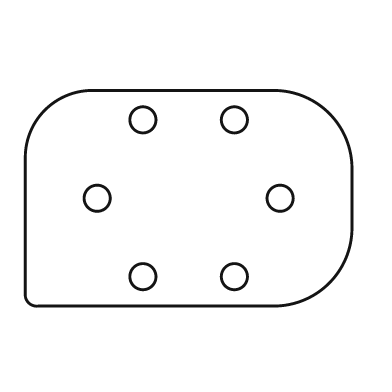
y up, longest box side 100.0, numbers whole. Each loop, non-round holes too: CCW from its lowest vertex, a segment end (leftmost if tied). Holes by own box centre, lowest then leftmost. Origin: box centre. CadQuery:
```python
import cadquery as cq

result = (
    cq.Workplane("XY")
    .moveTo(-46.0, -33.0)
    .lineTo(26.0, -33.0)
    .threePointArc((43.0, -26.0), (50.0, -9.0))
    .lineTo(50.0, 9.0)
    .threePointArc((43.0, 26.0), (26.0, 33.0))
    .lineTo(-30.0, 33.0)
    .threePointArc((-44.0, 27.0), (-50.0, 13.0))
    .lineTo(-50.0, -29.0)
    .threePointArc((-49.0, -32.0), (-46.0, -33.0))
    .close()
    .moveTo(-14.0, -24.0)
    .circle(4.0)
    .moveTo(14.0, -24.0)
    .circle(4.0)
    .moveTo(-28.0, 0.0)
    .circle(4.0)
    .moveTo(28.0, 0.0)
    .circle(4.0)
    .moveTo(-14.0, 24.0)
    .circle(4.0)
    .moveTo(14.0, 24.0)
    .circle(4.0)
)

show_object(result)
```